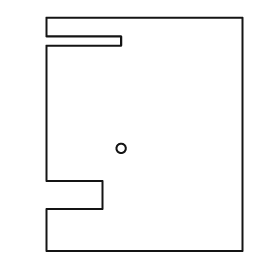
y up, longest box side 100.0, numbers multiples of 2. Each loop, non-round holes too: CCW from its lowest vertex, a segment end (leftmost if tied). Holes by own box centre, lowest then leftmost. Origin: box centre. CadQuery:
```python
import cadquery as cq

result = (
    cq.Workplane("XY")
    .moveTo(-42.0, -50.0)
    .lineTo(42.0, -50.0)
    .lineTo(42.0, 50.0)
    .lineTo(-42.0, 50.0)
    .lineTo(-42.0, 42.0)
    .lineTo(-10.0, 42.0)
    .lineTo(-10.0, 38.0)
    .lineTo(-42.0, 38.0)
    .lineTo(-42.0, -20.0)
    .lineTo(-18.0, -20.0)
    .lineTo(-18.0, -32.0)
    .lineTo(-42.0, -32.0)
    .close()
    .moveTo(-10.0, -6.0)
    .circle(2.0)
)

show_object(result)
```